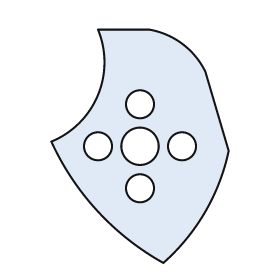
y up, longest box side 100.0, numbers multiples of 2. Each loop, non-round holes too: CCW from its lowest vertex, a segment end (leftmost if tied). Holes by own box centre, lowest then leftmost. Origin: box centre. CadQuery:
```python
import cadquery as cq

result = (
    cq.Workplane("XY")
    .moveTo(10.0, -50.0)
    .threePointArc((28.0, -28.0), (38.0, -2.0))
    .lineTo(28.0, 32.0)
    .threePointArc((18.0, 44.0), (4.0, 50.0))
    .lineTo(-18.0, 50.0)
    .threePointArc((-18.0, 22.0), (-38.0, 2.0))
    .threePointArc((-18.0, -28.0), (10.0, -50.0))
    .close()
    .moveTo(0.0, -18.0)
    .circle(6.0)
    .moveTo(-18.0, 0.0)
    .circle(6.0)
    .moveTo(0.0, 0.0)
    .circle(8.0)
    .moveTo(18.0, 0.0)
    .circle(6.0)
    .moveTo(0.0, 18.0)
    .circle(6.0)
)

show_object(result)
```